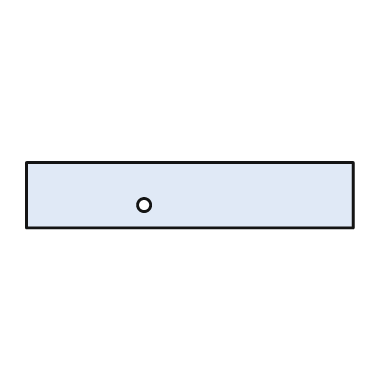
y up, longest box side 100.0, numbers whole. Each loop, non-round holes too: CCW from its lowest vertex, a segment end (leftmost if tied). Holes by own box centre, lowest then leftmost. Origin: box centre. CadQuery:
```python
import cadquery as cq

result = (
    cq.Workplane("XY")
    .moveTo(-50.0, -10.0)
    .lineTo(50.0, -10.0)
    .lineTo(50.0, 10.0)
    .lineTo(-50.0, 10.0)
    .close()
    .moveTo(-14.0, -3.0)
    .circle(2.0)
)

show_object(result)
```